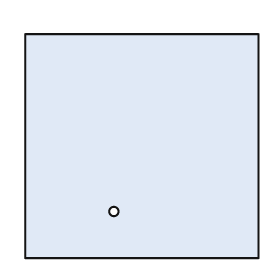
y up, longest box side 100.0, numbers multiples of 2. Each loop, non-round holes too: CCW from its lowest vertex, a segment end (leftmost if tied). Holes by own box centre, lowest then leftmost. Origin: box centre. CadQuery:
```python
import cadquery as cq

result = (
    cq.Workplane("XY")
    .moveTo(-50.0, -48.0)
    .lineTo(50.0, -48.0)
    .lineTo(50.0, 48.0)
    .lineTo(-50.0, 48.0)
    .close()
    .moveTo(-12.0, -28.0)
    .circle(2.0)
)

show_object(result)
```